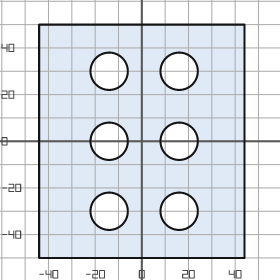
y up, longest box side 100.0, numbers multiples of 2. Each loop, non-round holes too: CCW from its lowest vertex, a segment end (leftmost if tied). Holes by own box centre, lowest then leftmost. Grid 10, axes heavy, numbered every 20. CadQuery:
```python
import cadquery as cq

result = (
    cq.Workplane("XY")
    .moveTo(-44.0, -50.0)
    .lineTo(44.0, -50.0)
    .lineTo(44.0, 50.0)
    .lineTo(-44.0, 50.0)
    .close()
    .moveTo(-14.0, -30.0)
    .circle(8.0)
    .moveTo(16.0, -30.0)
    .circle(8.0)
    .moveTo(-14.0, 0.0)
    .circle(8.0)
    .moveTo(16.0, 0.0)
    .circle(8.0)
    .moveTo(-14.0, 30.0)
    .circle(8.0)
    .moveTo(16.0, 30.0)
    .circle(8.0)
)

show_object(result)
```